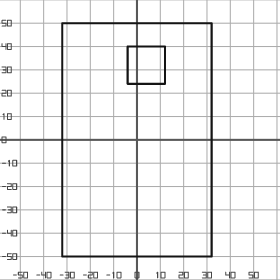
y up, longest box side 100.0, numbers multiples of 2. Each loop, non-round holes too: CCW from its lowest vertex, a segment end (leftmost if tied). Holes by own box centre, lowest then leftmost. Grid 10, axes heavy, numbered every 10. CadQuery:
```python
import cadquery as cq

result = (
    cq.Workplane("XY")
    .moveTo(-32.0, -50.0)
    .lineTo(32.0, -50.0)
    .lineTo(32.0, 50.0)
    .lineTo(-32.0, 50.0)
    .close()
    .moveTo(-4.0, 24.0)
    .lineTo(12.0, 24.0)
    .lineTo(12.0, 40.0)
    .lineTo(-4.0, 40.0)
    .close()
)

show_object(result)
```